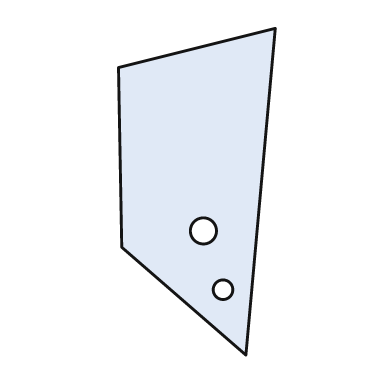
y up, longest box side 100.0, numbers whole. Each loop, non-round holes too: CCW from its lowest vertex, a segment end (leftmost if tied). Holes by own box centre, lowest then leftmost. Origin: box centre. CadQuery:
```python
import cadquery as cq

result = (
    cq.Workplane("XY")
    .moveTo(15.0, -50.0)
    .lineTo(24.0, 50.0)
    .lineTo(-24.0, 38.0)
    .lineTo(-23.0, -17.0)
    .close()
    .moveTo(8.0, -30.0)
    .circle(3.0)
    .moveTo(2.0, -12.0)
    .circle(4.0)
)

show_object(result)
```